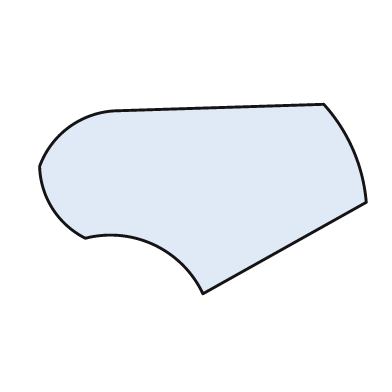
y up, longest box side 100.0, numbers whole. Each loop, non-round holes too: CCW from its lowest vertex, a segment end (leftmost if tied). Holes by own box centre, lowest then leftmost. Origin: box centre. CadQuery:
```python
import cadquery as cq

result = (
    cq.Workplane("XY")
    .moveTo(0.0, -29.0)
    .lineTo(50.0, -1.0)
    .threePointArc((46.0, 15.0), (37.0, 29.0))
    .lineTo(-27.0, 27.0)
    .threePointArc((-41.0, 22.0), (-50.0, 10.0))
    .threePointArc((-46.0, -3.0), (-36.0, -12.0))
    .threePointArc((-15.0, -14.0), (0.0, -29.0))
    .close()
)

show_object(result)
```